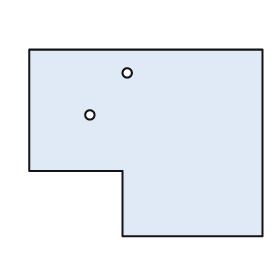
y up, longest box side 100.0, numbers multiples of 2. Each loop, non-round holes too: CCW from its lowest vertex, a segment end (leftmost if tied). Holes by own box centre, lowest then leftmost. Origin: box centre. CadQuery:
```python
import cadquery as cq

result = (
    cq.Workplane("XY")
    .moveTo(-10.0, -40.0)
    .lineTo(50.0, -40.0)
    .lineTo(50.0, 40.0)
    .lineTo(-50.0, 40.0)
    .lineTo(-50.0, -12.0)
    .lineTo(-10.0, -12.0)
    .close()
    .moveTo(-24.0, 12.0)
    .circle(2.0)
    .moveTo(-8.0, 30.0)
    .circle(2.0)
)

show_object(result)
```